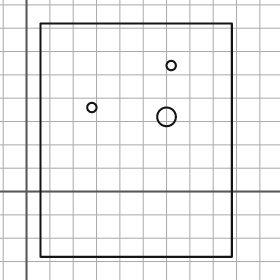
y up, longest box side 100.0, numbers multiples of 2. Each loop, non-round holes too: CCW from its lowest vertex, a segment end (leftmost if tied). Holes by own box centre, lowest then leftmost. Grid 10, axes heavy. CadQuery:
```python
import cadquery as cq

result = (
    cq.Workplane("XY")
    .moveTo(6.0, -28.0)
    .lineTo(88.0, -28.0)
    .lineTo(88.0, 72.0)
    .lineTo(6.0, 72.0)
    .close()
    .moveTo(60.0, 32.0)
    .circle(4.0)
    .moveTo(28.0, 36.0)
    .circle(2.0)
    .moveTo(62.0, 54.0)
    .circle(2.0)
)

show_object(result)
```